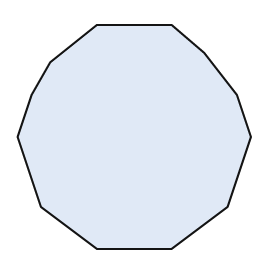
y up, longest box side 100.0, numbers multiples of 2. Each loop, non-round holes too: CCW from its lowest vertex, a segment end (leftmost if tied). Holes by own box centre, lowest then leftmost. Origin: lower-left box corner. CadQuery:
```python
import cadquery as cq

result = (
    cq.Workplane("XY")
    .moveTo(34.0, 0.0)
    .lineTo(66.0, 0.0)
    .lineTo(90.0, 18.0)
    .lineTo(100.0, 48.0)
    .lineTo(94.0, 66.0)
    .lineTo(80.0, 84.0)
    .lineTo(66.0, 96.0)
    .lineTo(34.0, 96.0)
    .lineTo(14.0, 80.0)
    .lineTo(6.0, 66.0)
    .lineTo(0.0, 48.0)
    .lineTo(10.0, 18.0)
    .close()
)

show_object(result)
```